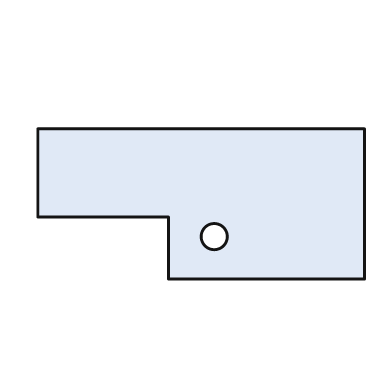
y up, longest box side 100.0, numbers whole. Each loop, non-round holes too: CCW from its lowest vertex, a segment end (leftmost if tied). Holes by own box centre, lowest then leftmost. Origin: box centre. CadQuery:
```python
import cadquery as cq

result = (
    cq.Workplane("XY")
    .moveTo(-10.0, -23.0)
    .lineTo(50.0, -23.0)
    .lineTo(50.0, 23.0)
    .lineTo(-50.0, 23.0)
    .lineTo(-50.0, -4.0)
    .lineTo(-10.0, -4.0)
    .close()
    .moveTo(4.0, -10.0)
    .circle(4.0)
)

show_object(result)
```